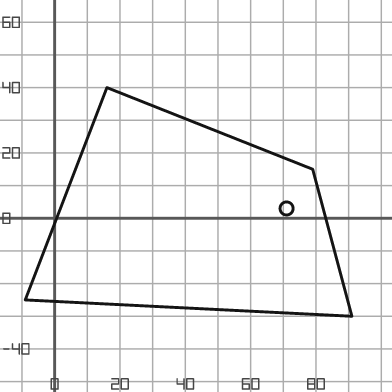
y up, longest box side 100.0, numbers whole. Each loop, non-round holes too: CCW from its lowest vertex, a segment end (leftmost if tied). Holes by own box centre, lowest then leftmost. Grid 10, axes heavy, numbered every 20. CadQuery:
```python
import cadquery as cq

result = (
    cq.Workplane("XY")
    .moveTo(91.0, -30.0)
    .lineTo(79.0, 15.0)
    .lineTo(16.0, 40.0)
    .lineTo(-9.0, -25.0)
    .close()
    .moveTo(71.0, 3.0)
    .circle(2.0)
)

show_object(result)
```